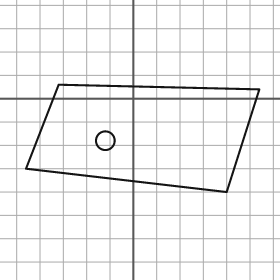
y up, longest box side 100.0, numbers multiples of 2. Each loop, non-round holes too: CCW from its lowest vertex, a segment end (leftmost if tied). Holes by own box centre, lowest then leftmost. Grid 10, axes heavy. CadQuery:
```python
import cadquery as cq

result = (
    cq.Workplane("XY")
    .moveTo(40.0, -40.0)
    .lineTo(54.0, 4.0)
    .lineTo(-32.0, 6.0)
    .lineTo(-46.0, -30.0)
    .close()
    .moveTo(-12.0, -18.0)
    .circle(4.0)
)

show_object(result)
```